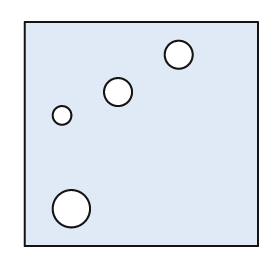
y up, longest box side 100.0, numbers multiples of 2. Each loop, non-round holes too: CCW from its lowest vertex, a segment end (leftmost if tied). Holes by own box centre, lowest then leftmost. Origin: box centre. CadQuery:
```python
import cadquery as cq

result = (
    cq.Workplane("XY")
    .moveTo(-50.0, -48.0)
    .lineTo(50.0, -48.0)
    .lineTo(50.0, 48.0)
    .lineTo(-50.0, 48.0)
    .close()
    .moveTo(-30.0, -32.0)
    .circle(8.0)
    .moveTo(-34.0, 8.0)
    .circle(4.0)
    .moveTo(-10.0, 18.0)
    .circle(6.0)
    .moveTo(16.0, 34.0)
    .circle(6.0)
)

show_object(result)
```